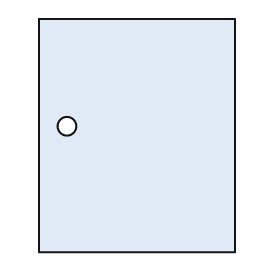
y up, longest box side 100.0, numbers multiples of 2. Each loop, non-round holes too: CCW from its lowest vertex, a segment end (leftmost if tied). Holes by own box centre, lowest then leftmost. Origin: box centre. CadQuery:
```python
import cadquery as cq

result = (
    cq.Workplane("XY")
    .moveTo(-42.0, -50.0)
    .lineTo(42.0, -50.0)
    .lineTo(42.0, 50.0)
    .lineTo(-42.0, 50.0)
    .close()
    .moveTo(-30.0, 4.0)
    .circle(4.0)
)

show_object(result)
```